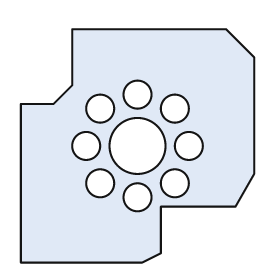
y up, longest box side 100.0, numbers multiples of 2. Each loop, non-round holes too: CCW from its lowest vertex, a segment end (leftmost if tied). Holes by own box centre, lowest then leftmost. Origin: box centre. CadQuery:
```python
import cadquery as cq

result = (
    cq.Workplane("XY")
    .moveTo(-50.0, -50.0)
    .lineTo(2.0, -50.0)
    .lineTo(10.0, -46.0)
    .lineTo(10.0, -26.0)
    .lineTo(42.0, -26.0)
    .lineTo(50.0, -12.0)
    .lineTo(50.0, 38.0)
    .lineTo(38.0, 50.0)
    .lineTo(-28.0, 50.0)
    .lineTo(-28.0, 26.0)
    .lineTo(-36.0, 18.0)
    .lineTo(-50.0, 18.0)
    .close()
    .moveTo(0.0, -22.0)
    .circle(6.0)
    .moveTo(-16.0, -16.0)
    .circle(6.0)
    .moveTo(16.0, -16.0)
    .circle(6.0)
    .moveTo(-22.0, 0.0)
    .circle(6.0)
    .moveTo(0.0, 0.0)
    .circle(12.0)
    .moveTo(22.0, 0.0)
    .circle(6.0)
    .moveTo(-16.0, 16.0)
    .circle(6.0)
    .moveTo(16.0, 16.0)
    .circle(6.0)
    .moveTo(0.0, 22.0)
    .circle(6.0)
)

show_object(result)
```